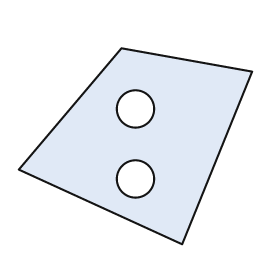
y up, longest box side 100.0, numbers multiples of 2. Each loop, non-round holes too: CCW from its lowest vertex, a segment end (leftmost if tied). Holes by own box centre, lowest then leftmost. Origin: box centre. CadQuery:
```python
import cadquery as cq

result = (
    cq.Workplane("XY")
    .moveTo(20.0, -42.0)
    .lineTo(50.0, 32.0)
    .lineTo(-6.0, 42.0)
    .lineTo(-50.0, -10.0)
    .close()
    .moveTo(0.0, -14.0)
    .circle(8.0)
    .moveTo(0.0, 16.0)
    .circle(8.0)
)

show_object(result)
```